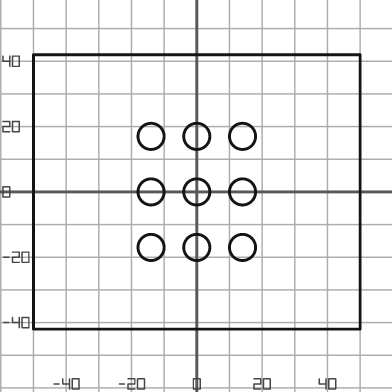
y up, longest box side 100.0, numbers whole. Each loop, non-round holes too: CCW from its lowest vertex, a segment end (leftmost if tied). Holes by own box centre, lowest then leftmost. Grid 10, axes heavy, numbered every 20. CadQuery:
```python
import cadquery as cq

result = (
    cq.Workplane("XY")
    .moveTo(-50.0, -42.0)
    .lineTo(50.0, -42.0)
    .lineTo(50.0, 42.0)
    .lineTo(-50.0, 42.0)
    .close()
    .moveTo(-14.0, -17.0)
    .circle(4.0)
    .moveTo(0.0, -17.0)
    .circle(4.0)
    .moveTo(14.0, -17.0)
    .circle(4.0)
    .moveTo(-14.0, 0.0)
    .circle(4.0)
    .moveTo(0.0, 0.0)
    .circle(4.0)
    .moveTo(14.0, 0.0)
    .circle(4.0)
    .moveTo(-14.0, 17.0)
    .circle(4.0)
    .moveTo(0.0, 17.0)
    .circle(4.0)
    .moveTo(14.0, 17.0)
    .circle(4.0)
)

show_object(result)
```